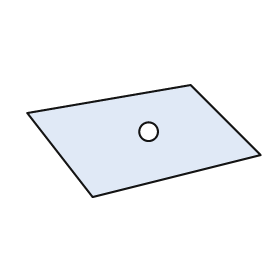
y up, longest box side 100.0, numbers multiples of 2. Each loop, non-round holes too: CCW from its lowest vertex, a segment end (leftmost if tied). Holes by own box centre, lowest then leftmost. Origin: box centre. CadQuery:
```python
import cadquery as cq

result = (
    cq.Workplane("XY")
    .moveTo(-22.0, -24.0)
    .lineTo(50.0, -6.0)
    .lineTo(20.0, 24.0)
    .lineTo(-50.0, 12.0)
    .close()
    .moveTo(2.0, 4.0)
    .circle(4.0)
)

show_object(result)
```